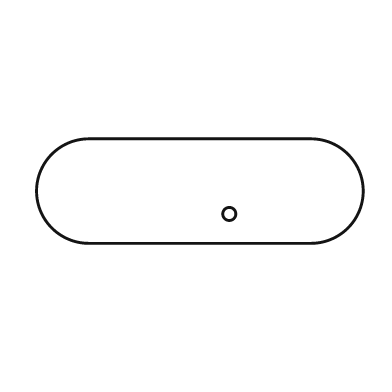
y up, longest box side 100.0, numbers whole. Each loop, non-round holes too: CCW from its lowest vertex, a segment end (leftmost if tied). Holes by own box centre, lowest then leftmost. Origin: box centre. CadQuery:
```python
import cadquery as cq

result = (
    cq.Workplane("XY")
    .moveTo(-34.0, -16.0)
    .lineTo(34.0, -16.0)
    .threePointArc((50.0, 0.0), (34.0, 16.0))
    .lineTo(-34.0, 16.0)
    .threePointArc((-50.0, 0.0), (-34.0, -16.0))
    .close()
    .moveTo(9.0, -7.0)
    .circle(2.0)
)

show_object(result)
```